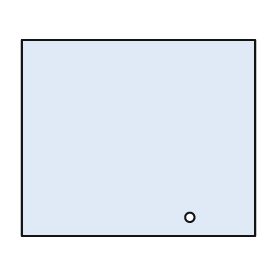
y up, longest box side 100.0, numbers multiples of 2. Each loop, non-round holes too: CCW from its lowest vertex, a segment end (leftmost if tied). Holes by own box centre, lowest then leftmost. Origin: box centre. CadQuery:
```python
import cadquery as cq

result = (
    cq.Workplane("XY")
    .moveTo(-50.0, -42.0)
    .lineTo(50.0, -42.0)
    .lineTo(50.0, 42.0)
    .lineTo(-50.0, 42.0)
    .close()
    .moveTo(22.0, -34.0)
    .circle(2.0)
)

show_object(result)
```